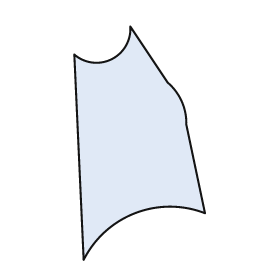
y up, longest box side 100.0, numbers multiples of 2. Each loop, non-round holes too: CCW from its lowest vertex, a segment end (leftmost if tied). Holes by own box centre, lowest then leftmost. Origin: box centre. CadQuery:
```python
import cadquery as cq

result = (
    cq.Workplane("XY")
    .moveTo(-24.0, -50.0)
    .threePointArc((-2.0, -30.0), (28.0, -30.0))
    .lineTo(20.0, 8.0)
    .threePointArc((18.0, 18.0), (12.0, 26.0))
    .lineTo(-4.0, 50.0)
    .threePointArc((-12.0, 36.0), (-28.0, 38.0))
    .close()
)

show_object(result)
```